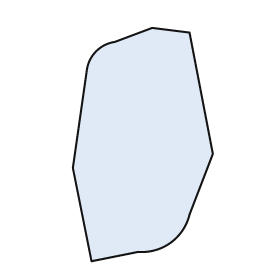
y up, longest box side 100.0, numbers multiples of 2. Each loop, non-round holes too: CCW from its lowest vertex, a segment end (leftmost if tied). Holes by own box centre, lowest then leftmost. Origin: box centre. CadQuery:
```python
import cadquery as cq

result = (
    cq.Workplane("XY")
    .moveTo(-22.0, -50.0)
    .lineTo(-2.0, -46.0)
    .threePointArc((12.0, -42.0), (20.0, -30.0))
    .lineTo(30.0, -4.0)
    .lineTo(20.0, 48.0)
    .lineTo(4.0, 50.0)
    .lineTo(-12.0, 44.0)
    .threePointArc((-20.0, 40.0), (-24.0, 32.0))
    .lineTo(-30.0, -10.0)
    .close()
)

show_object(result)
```